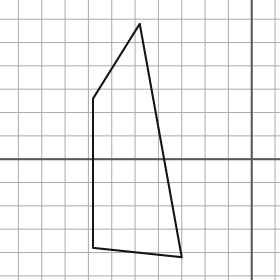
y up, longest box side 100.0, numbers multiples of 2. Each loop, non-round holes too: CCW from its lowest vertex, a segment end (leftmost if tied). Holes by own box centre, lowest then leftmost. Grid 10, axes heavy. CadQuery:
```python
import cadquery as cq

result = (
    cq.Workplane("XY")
    .moveTo(-30.0, -42.0)
    .lineTo(-48.0, 58.0)
    .lineTo(-68.0, 26.0)
    .lineTo(-68.0, -38.0)
    .close()
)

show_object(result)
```